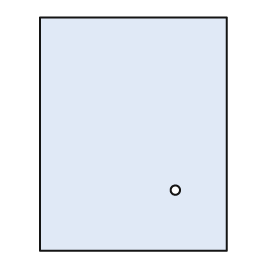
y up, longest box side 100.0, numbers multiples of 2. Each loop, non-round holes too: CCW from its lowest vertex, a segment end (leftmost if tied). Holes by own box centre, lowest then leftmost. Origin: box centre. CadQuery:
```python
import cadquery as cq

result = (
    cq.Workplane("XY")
    .moveTo(-40.0, -50.0)
    .lineTo(40.0, -50.0)
    .lineTo(40.0, 50.0)
    .lineTo(-40.0, 50.0)
    .close()
    .moveTo(18.0, -24.0)
    .circle(2.0)
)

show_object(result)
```